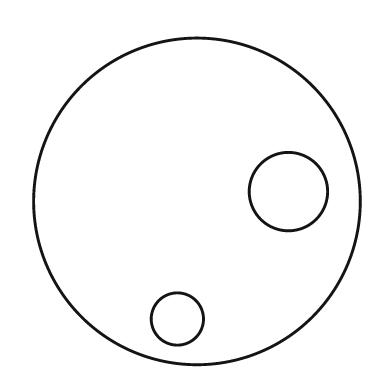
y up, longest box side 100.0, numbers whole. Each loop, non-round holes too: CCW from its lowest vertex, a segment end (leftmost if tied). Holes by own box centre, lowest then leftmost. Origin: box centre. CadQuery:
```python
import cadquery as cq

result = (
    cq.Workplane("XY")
    .moveTo(0.0, 0.0)
    .circle(50.0)
    .moveTo(-6.0, -36.0)
    .circle(8.0)
    .moveTo(28.0, 3.0)
    .circle(12.0)
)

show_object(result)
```